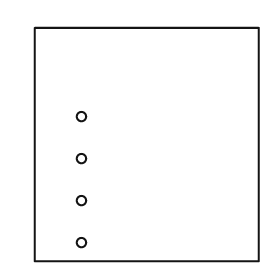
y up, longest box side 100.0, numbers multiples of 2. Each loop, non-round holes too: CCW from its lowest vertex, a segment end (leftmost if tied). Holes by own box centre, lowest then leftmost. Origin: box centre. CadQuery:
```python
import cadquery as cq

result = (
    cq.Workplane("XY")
    .moveTo(-48.0, -50.0)
    .lineTo(48.0, -50.0)
    .lineTo(48.0, 50.0)
    .lineTo(-48.0, 50.0)
    .close()
    .moveTo(-28.0, -42.0)
    .circle(2.0)
    .moveTo(-28.0, -24.0)
    .circle(2.0)
    .moveTo(-28.0, -6.0)
    .circle(2.0)
    .moveTo(-28.0, 12.0)
    .circle(2.0)
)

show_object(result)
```